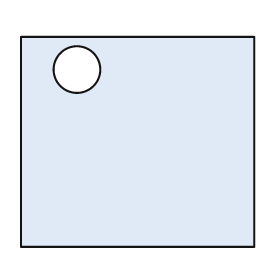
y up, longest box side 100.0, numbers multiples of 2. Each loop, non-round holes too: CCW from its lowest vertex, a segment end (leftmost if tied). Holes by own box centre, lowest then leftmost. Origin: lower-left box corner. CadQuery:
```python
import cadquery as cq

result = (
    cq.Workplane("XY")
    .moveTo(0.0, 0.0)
    .lineTo(100.0, 0.0)
    .lineTo(100.0, 90.0)
    .lineTo(0.0, 90.0)
    .close()
    .moveTo(24.0, 76.0)
    .circle(10.0)
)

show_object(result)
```